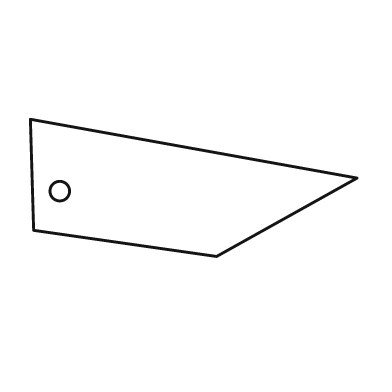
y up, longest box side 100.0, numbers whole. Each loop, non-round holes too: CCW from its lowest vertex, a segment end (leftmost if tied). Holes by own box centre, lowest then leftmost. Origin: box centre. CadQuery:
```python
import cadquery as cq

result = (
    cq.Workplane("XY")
    .moveTo(7.0, -21.0)
    .lineTo(50.0, 3.0)
    .lineTo(-50.0, 21.0)
    .lineTo(-49.0, -13.0)
    .close()
    .moveTo(-41.0, -1.0)
    .circle(3.0)
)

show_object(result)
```